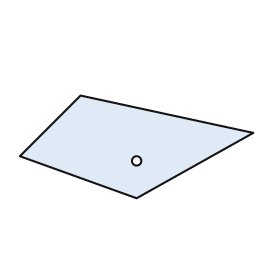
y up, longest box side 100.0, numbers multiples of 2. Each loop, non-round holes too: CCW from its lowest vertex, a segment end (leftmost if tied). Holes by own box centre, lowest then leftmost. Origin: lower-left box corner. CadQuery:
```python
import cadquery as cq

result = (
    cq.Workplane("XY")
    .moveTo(50.0, 0.0)
    .lineTo(100.0, 28.0)
    .lineTo(26.0, 44.0)
    .lineTo(0.0, 18.0)
    .close()
    .moveTo(50.0, 16.0)
    .circle(2.0)
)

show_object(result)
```